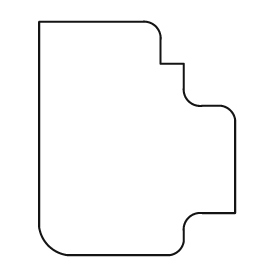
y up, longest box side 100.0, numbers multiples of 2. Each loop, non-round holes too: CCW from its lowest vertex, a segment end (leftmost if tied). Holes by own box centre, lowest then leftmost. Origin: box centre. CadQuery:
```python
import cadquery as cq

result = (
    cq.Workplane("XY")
    .moveTo(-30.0, -50.0)
    .lineTo(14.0, -50.0)
    .threePointArc((18.0, -48.0), (20.0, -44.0))
    .lineTo(20.0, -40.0)
    .threePointArc((22.0, -34.0), (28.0, -32.0))
    .lineTo(42.0, -32.0)
    .lineTo(42.0, 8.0)
    .threePointArc((40.0, 12.0), (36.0, 14.0))
    .lineTo(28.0, 14.0)
    .threePointArc((22.0, 16.0), (20.0, 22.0))
    .lineTo(20.0, 32.0)
    .lineTo(10.0, 32.0)
    .lineTo(10.0, 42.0)
    .threePointArc((8.0, 48.0), (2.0, 50.0))
    .lineTo(-42.0, 50.0)
    .lineTo(-42.0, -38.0)
    .threePointArc((-38.0, -46.0), (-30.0, -50.0))
    .close()
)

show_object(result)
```